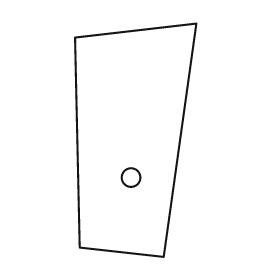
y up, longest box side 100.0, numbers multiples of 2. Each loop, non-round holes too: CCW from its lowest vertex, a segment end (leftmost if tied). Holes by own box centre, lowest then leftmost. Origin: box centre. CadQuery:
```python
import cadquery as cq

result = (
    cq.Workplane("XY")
    .moveTo(12.0, -50.0)
    .lineTo(26.0, 50.0)
    .lineTo(-26.0, 44.0)
    .lineTo(-24.0, -46.0)
    .close()
    .moveTo(-2.0, -16.0)
    .circle(4.0)
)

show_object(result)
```